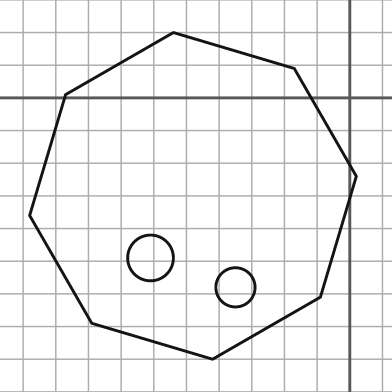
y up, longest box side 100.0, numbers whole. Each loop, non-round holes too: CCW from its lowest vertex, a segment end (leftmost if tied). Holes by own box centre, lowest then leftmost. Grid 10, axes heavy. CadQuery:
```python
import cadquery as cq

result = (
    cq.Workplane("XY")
    .moveTo(-42.0, -80.0)
    .lineTo(-9.0, -61.0)
    .lineTo(2.0, -24.0)
    .lineTo(-17.0, 9.0)
    .lineTo(-54.0, 20.0)
    .lineTo(-87.0, 1.0)
    .lineTo(-98.0, -36.0)
    .lineTo(-79.0, -69.0)
    .close()
    .moveTo(-35.0, -58.0)
    .circle(6.0)
    .moveTo(-61.0, -49.0)
    .circle(7.0)
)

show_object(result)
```